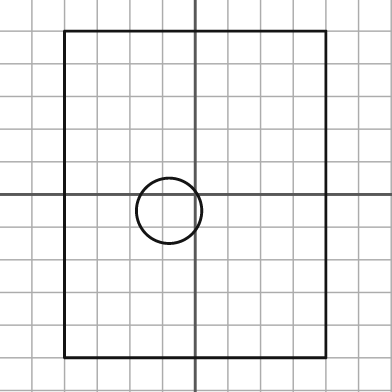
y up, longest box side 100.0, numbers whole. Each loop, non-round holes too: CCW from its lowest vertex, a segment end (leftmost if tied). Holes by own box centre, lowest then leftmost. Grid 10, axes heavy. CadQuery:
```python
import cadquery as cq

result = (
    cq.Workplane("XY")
    .moveTo(-40.0, -50.0)
    .lineTo(40.0, -50.0)
    .lineTo(40.0, 50.0)
    .lineTo(-40.0, 50.0)
    .close()
    .moveTo(-8.0, -5.0)
    .circle(10.0)
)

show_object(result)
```